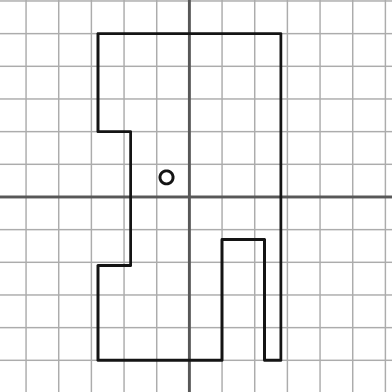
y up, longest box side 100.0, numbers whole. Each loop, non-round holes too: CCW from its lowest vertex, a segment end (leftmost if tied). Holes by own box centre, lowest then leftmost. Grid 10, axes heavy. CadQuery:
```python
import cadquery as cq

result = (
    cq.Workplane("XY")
    .moveTo(-28.0, -50.0)
    .lineTo(10.0, -50.0)
    .lineTo(10.0, -13.0)
    .lineTo(23.0, -13.0)
    .lineTo(23.0, -50.0)
    .lineTo(28.0, -50.0)
    .lineTo(28.0, 50.0)
    .lineTo(-28.0, 50.0)
    .lineTo(-28.0, 20.0)
    .lineTo(-18.0, 20.0)
    .lineTo(-18.0, -21.0)
    .lineTo(-28.0, -21.0)
    .close()
    .moveTo(-7.0, 6.0)
    .circle(2.0)
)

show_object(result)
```